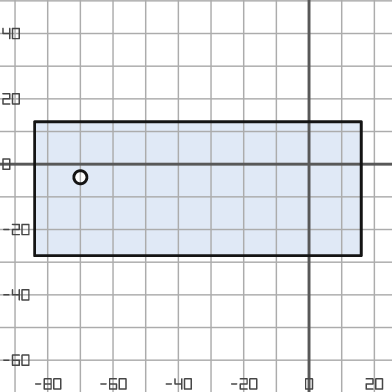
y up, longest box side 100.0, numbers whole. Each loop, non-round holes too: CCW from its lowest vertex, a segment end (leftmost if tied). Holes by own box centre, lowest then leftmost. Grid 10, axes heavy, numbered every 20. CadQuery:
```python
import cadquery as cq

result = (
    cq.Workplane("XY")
    .moveTo(-84.0, -28.0)
    .lineTo(16.0, -28.0)
    .lineTo(16.0, 13.0)
    .lineTo(-84.0, 13.0)
    .close()
    .moveTo(-70.0, -4.0)
    .circle(2.0)
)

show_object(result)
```